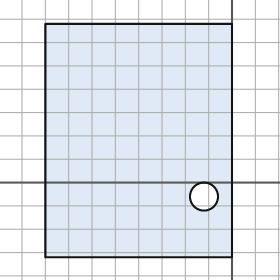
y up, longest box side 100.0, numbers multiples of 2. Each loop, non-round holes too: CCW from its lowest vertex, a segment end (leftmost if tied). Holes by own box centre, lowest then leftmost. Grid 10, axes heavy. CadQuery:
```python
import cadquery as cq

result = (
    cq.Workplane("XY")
    .moveTo(-80.0, -32.0)
    .lineTo(0.0, -32.0)
    .lineTo(0.0, 68.0)
    .lineTo(-80.0, 68.0)
    .close()
    .moveTo(-12.0, -6.0)
    .circle(6.0)
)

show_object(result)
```